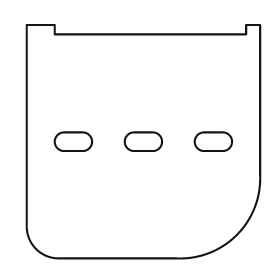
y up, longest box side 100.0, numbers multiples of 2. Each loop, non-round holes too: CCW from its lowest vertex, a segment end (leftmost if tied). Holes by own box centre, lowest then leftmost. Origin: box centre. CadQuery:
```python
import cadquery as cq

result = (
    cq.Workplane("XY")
    .moveTo(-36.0, -50.0)
    .lineTo(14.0, -50.0)
    .threePointArc((40.0, -40.0), (50.0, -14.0))
    .lineTo(50.0, 50.0)
    .lineTo(44.0, 50.0)
    .lineTo(44.0, 46.0)
    .lineTo(-38.0, 46.0)
    .lineTo(-38.0, 50.0)
    .lineTo(-50.0, 50.0)
    .lineTo(-50.0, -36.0)
    .threePointArc((-46.0, -46.0), (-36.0, -50.0))
    .close()
    .moveTo(-34.0, -4.0)
    .lineTo(-26.0, -4.0)
    .threePointArc((-22.0, 0.0), (-26.0, 4.0))
    .lineTo(-34.0, 4.0)
    .threePointArc((-38.0, 0.0), (-34.0, -4.0))
    .close()
    .moveTo(-4.0, -4.0)
    .lineTo(4.0, -4.0)
    .threePointArc((8.0, 0.0), (4.0, 4.0))
    .lineTo(-4.0, 4.0)
    .threePointArc((-8.0, 0.0), (-4.0, -4.0))
    .close()
    .moveTo(26.0, -4.0)
    .lineTo(34.0, -4.0)
    .threePointArc((38.0, 0.0), (34.0, 4.0))
    .lineTo(26.0, 4.0)
    .threePointArc((22.0, 0.0), (26.0, -4.0))
    .close()
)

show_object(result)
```